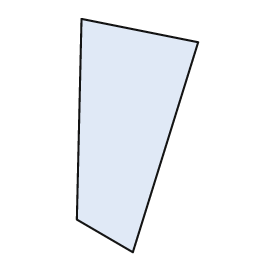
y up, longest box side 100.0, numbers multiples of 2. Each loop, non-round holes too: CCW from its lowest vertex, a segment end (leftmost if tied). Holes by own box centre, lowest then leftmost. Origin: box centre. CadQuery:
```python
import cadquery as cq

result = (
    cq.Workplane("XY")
    .moveTo(-2.0, -50.0)
    .lineTo(26.0, 40.0)
    .lineTo(-24.0, 50.0)
    .lineTo(-26.0, -36.0)
    .close()
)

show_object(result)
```